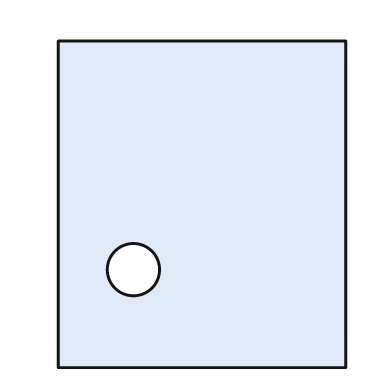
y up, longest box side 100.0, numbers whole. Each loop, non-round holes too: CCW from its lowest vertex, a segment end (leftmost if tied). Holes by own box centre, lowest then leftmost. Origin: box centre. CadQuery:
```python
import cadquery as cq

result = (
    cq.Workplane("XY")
    .moveTo(-44.0, -50.0)
    .lineTo(44.0, -50.0)
    .lineTo(44.0, 50.0)
    .lineTo(-44.0, 50.0)
    .close()
    .moveTo(-21.0, -20.0)
    .circle(8.0)
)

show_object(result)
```